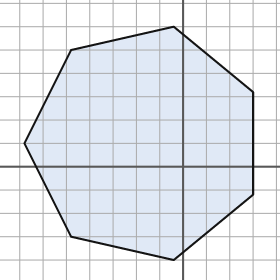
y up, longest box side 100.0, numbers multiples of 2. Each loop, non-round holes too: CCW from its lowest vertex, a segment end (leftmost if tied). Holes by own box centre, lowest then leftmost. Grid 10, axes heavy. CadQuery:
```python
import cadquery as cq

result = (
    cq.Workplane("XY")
    .moveTo(-4.0, -40.0)
    .lineTo(30.0, -12.0)
    .lineTo(30.0, 32.0)
    .lineTo(-4.0, 60.0)
    .lineTo(-48.0, 50.0)
    .lineTo(-68.0, 10.0)
    .lineTo(-48.0, -30.0)
    .close()
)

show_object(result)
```